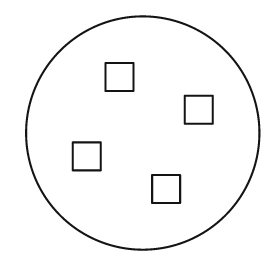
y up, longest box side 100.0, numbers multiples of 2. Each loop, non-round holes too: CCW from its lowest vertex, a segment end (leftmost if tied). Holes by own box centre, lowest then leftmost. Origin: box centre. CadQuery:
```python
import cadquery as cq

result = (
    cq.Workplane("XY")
    .moveTo(0.0, 0.0)
    .circle(50.0)
    .moveTo(4.0, -30.0)
    .lineTo(16.0, -30.0)
    .lineTo(16.0, -18.0)
    .lineTo(4.0, -18.0)
    .close()
    .moveTo(-30.0, -16.0)
    .lineTo(-18.0, -16.0)
    .lineTo(-18.0, -4.0)
    .lineTo(-30.0, -4.0)
    .close()
    .moveTo(18.0, 4.0)
    .lineTo(30.0, 4.0)
    .lineTo(30.0, 16.0)
    .lineTo(18.0, 16.0)
    .close()
    .moveTo(-16.0, 18.0)
    .lineTo(-4.0, 18.0)
    .lineTo(-4.0, 30.0)
    .lineTo(-16.0, 30.0)
    .close()
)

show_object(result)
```